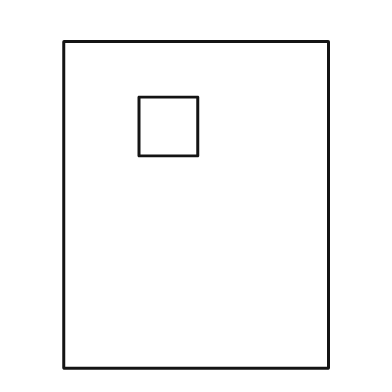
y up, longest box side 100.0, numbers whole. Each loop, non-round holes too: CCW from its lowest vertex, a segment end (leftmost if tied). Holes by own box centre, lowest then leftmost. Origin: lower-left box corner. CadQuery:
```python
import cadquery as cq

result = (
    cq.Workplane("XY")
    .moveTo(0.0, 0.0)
    .lineTo(81.0, 0.0)
    .lineTo(81.0, 100.0)
    .lineTo(0.0, 100.0)
    .close()
    .moveTo(23.0, 65.0)
    .lineTo(41.0, 65.0)
    .lineTo(41.0, 83.0)
    .lineTo(23.0, 83.0)
    .close()
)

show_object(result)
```